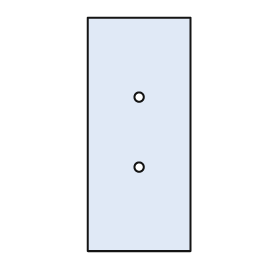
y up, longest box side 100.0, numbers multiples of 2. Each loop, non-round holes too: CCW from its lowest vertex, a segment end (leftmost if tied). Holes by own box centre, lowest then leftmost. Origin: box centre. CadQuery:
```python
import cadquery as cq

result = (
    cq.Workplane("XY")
    .moveTo(-22.0, -50.0)
    .lineTo(22.0, -50.0)
    .lineTo(22.0, 50.0)
    .lineTo(-22.0, 50.0)
    .close()
    .moveTo(0.0, -14.0)
    .circle(2.0)
    .moveTo(0.0, 16.0)
    .circle(2.0)
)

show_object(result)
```